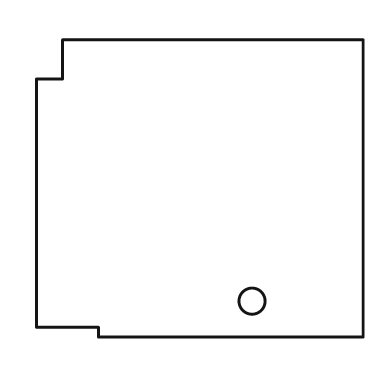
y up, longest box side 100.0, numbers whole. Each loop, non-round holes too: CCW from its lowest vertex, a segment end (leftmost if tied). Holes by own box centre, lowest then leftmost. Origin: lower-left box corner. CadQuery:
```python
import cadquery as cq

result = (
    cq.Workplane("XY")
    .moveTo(19.0, 0.0)
    .lineTo(100.0, 0.0)
    .lineTo(100.0, 91.0)
    .lineTo(8.0, 91.0)
    .lineTo(8.0, 79.0)
    .lineTo(0.0, 79.0)
    .lineTo(0.0, 3.0)
    .lineTo(19.0, 3.0)
    .close()
    .moveTo(66.0, 11.0)
    .circle(4.0)
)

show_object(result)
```